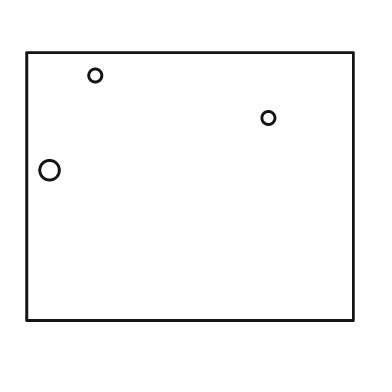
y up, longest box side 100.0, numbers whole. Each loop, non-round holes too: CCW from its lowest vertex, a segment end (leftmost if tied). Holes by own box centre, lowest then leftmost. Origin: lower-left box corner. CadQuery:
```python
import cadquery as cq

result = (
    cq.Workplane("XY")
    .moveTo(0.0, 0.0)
    .lineTo(100.0, 0.0)
    .lineTo(100.0, 82.0)
    .lineTo(0.0, 82.0)
    .close()
    .moveTo(7.0, 46.0)
    .circle(3.0)
    .moveTo(74.0, 62.0)
    .circle(2.0)
    .moveTo(21.0, 75.0)
    .circle(2.0)
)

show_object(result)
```